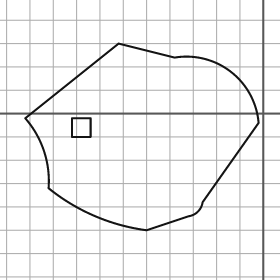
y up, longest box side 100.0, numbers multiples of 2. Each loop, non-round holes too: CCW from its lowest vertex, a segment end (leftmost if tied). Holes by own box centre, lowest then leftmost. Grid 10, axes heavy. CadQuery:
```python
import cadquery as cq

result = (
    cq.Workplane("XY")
    .moveTo(-50.0, -50.0)
    .lineTo(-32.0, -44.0)
    .threePointArc((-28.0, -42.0), (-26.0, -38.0))
    .lineTo(-2.0, -4.0)
    .threePointArc((-14.0, 18.0), (-38.0, 24.0))
    .lineTo(-62.0, 30.0)
    .lineTo(-102.0, -2.0)
    .threePointArc((-94.0, -16.0), (-92.0, -32.0))
    .threePointArc((-72.0, -44.0), (-50.0, -50.0))
    .close()
    .moveTo(-82.0, -10.0)
    .lineTo(-74.0, -10.0)
    .lineTo(-74.0, -2.0)
    .lineTo(-82.0, -2.0)
    .close()
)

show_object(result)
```